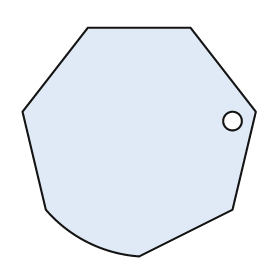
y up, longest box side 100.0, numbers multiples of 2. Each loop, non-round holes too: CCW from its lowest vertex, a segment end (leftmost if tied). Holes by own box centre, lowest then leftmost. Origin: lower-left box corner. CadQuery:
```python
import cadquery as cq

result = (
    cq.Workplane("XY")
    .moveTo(50.0, 0.0)
    .lineTo(90.0, 20.0)
    .lineTo(100.0, 62.0)
    .lineTo(72.0, 98.0)
    .lineTo(28.0, 98.0)
    .lineTo(0.0, 62.0)
    .lineTo(10.0, 20.0)
    .threePointArc((28.0, 6.0), (50.0, 0.0))
    .close()
    .moveTo(90.0, 58.0)
    .circle(4.0)
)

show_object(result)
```